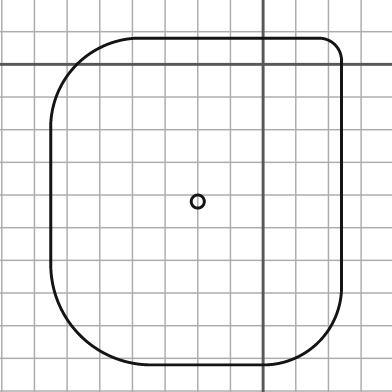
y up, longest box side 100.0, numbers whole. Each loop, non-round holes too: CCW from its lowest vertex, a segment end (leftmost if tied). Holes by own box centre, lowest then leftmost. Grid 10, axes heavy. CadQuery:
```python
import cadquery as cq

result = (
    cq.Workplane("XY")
    .moveTo(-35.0, -92.0)
    .lineTo(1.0, -92.0)
    .threePointArc((17.0, -85.0), (24.0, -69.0))
    .lineTo(24.0, 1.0)
    .threePointArc((22.0, 6.0), (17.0, 8.0))
    .lineTo(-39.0, 8.0)
    .threePointArc((-57.0, 0.0), (-65.0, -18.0))
    .lineTo(-65.0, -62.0)
    .threePointArc((-56.0, -83.0), (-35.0, -92.0))
    .close()
    .moveTo(-20.0, -42.0)
    .circle(2.0)
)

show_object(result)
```